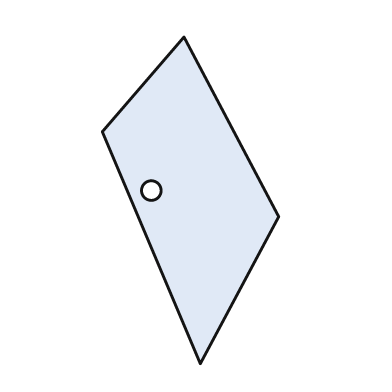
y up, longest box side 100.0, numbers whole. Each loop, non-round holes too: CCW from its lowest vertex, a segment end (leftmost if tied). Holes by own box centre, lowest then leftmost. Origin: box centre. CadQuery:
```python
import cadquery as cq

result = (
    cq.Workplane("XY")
    .moveTo(3.0, -50.0)
    .lineTo(27.0, -5.0)
    .lineTo(-2.0, 50.0)
    .lineTo(-27.0, 21.0)
    .close()
    .moveTo(-12.0, 3.0)
    .circle(3.0)
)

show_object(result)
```